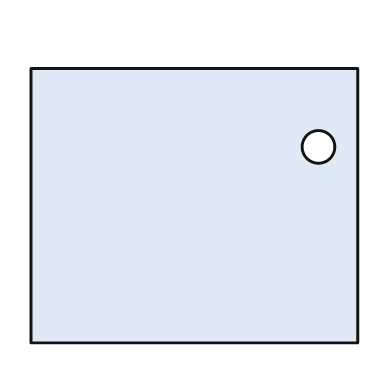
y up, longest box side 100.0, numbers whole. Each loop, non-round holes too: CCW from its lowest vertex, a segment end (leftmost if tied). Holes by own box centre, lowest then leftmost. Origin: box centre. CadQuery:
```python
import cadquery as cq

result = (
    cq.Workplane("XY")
    .moveTo(-50.0, -42.0)
    .lineTo(50.0, -42.0)
    .lineTo(50.0, 42.0)
    .lineTo(-50.0, 42.0)
    .close()
    .moveTo(38.0, 18.0)
    .circle(5.0)
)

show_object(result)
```